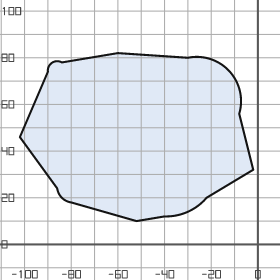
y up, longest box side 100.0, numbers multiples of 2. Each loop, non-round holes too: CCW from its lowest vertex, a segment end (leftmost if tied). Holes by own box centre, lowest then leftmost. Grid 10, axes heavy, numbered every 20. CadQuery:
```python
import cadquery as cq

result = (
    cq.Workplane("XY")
    .moveTo(-52.0, 10.0)
    .lineTo(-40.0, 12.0)
    .threePointArc((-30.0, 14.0), (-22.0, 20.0))
    .lineTo(-2.0, 32.0)
    .lineTo(-8.0, 56.0)
    .threePointArc((-12.0, 74.0), (-30.0, 80.0))
    .lineTo(-60.0, 82.0)
    .lineTo(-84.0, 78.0)
    .threePointArc((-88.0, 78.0), (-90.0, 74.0))
    .lineTo(-102.0, 46.0)
    .lineTo(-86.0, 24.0)
    .threePointArc((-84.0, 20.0), (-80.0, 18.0))
    .close()
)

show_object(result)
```